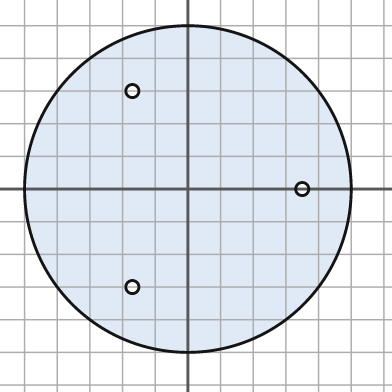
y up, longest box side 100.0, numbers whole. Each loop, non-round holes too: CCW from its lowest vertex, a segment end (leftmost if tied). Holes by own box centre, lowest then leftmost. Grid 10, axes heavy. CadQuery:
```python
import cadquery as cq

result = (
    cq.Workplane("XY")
    .moveTo(0.0, 0.0)
    .circle(50.0)
    .moveTo(-17.0, -30.0)
    .circle(2.0)
    .moveTo(35.0, 0.0)
    .circle(2.0)
    .moveTo(-17.0, 30.0)
    .circle(2.0)
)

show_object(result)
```